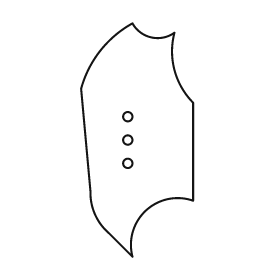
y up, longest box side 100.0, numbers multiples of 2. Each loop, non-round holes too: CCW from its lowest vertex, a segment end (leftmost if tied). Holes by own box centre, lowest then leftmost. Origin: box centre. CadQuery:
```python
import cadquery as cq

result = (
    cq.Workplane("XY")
    .moveTo(-2.0, -50.0)
    .threePointArc((4.0, -30.0), (24.0, -26.0))
    .lineTo(24.0, 16.0)
    .threePointArc((16.0, 30.0), (16.0, 46.0))
    .threePointArc((6.0, 44.0), (-2.0, 50.0))
    .threePointArc((-16.0, 38.0), (-24.0, 22.0))
    .lineTo(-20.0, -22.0)
    .threePointArc((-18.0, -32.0), (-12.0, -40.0))
    .close()
    .moveTo(-4.0, -10.0)
    .circle(2.0)
    .moveTo(-4.0, 0.0)
    .circle(2.0)
    .moveTo(-4.0, 10.0)
    .circle(2.0)
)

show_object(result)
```